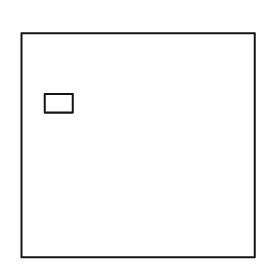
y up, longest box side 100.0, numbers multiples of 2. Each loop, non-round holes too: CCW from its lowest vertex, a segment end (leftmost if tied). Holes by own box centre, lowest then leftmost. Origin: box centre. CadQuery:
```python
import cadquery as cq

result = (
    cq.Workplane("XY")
    .moveTo(-50.0, -48.0)
    .lineTo(50.0, -48.0)
    .lineTo(50.0, 48.0)
    .lineTo(-50.0, 48.0)
    .close()
    .moveTo(-40.0, 14.0)
    .lineTo(-28.0, 14.0)
    .lineTo(-28.0, 22.0)
    .lineTo(-40.0, 22.0)
    .close()
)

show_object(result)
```